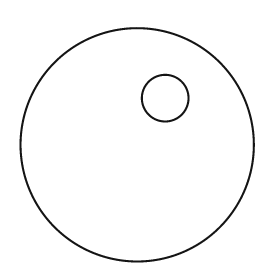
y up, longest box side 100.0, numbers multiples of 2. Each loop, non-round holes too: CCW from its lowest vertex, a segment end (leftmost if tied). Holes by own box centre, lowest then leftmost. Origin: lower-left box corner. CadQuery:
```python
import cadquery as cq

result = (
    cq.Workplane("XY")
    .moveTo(50.0, 50.0)
    .circle(50.0)
    .moveTo(62.0, 70.0)
    .circle(10.0)
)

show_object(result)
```